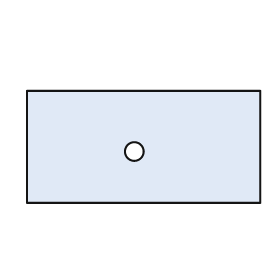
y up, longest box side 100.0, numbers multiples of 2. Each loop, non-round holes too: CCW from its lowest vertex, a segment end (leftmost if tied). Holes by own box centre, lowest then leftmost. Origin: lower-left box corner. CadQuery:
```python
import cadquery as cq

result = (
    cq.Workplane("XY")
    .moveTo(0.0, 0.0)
    .lineTo(100.0, 0.0)
    .lineTo(100.0, 48.0)
    .lineTo(0.0, 48.0)
    .close()
    .moveTo(46.0, 22.0)
    .circle(4.0)
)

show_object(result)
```